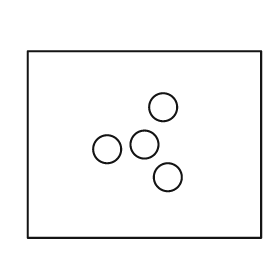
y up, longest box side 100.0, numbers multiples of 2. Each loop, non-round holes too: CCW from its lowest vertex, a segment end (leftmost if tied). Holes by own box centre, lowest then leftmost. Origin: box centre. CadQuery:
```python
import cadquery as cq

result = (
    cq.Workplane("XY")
    .moveTo(-50.0, -40.0)
    .lineTo(50.0, -40.0)
    .lineTo(50.0, 40.0)
    .lineTo(-50.0, 40.0)
    .close()
    .moveTo(10.0, -14.0)
    .circle(6.0)
    .moveTo(-16.0, -2.0)
    .circle(6.0)
    .moveTo(0.0, 0.0)
    .circle(6.0)
    .moveTo(8.0, 16.0)
    .circle(6.0)
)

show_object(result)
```